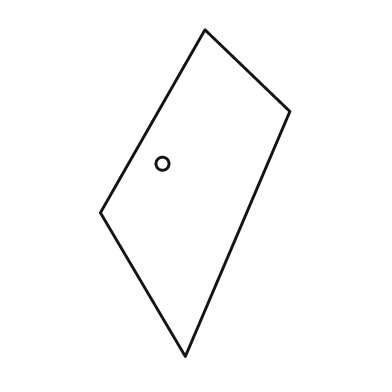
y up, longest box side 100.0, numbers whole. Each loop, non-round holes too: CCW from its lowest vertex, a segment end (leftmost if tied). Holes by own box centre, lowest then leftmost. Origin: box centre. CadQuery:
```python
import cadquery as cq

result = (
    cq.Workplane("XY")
    .moveTo(-3.0, -50.0)
    .lineTo(29.0, 25.0)
    .lineTo(3.0, 50.0)
    .lineTo(-29.0, -6.0)
    .close()
    .moveTo(-10.0, 9.0)
    .circle(2.0)
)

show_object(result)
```